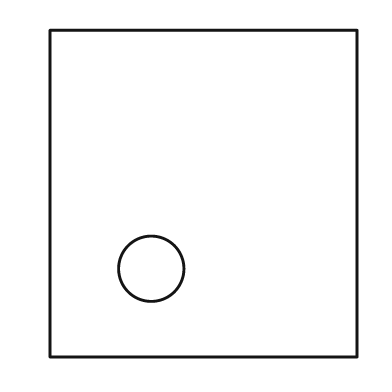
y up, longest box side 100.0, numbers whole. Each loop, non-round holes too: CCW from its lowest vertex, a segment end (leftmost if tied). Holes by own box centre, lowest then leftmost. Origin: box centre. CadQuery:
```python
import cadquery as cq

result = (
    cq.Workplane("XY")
    .moveTo(-47.0, -50.0)
    .lineTo(47.0, -50.0)
    .lineTo(47.0, 50.0)
    .lineTo(-47.0, 50.0)
    .close()
    .moveTo(-16.0, -23.0)
    .circle(10.0)
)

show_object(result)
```